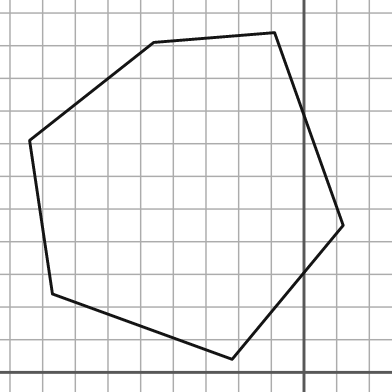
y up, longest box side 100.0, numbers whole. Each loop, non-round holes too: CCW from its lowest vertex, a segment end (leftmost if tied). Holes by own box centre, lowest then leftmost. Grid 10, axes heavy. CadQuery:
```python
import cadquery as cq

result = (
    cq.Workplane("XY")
    .moveTo(-22.0, 4.0)
    .lineTo(12.0, 45.0)
    .lineTo(-9.0, 104.0)
    .lineTo(-46.0, 101.0)
    .lineTo(-84.0, 71.0)
    .lineTo(-77.0, 24.0)
    .close()
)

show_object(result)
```